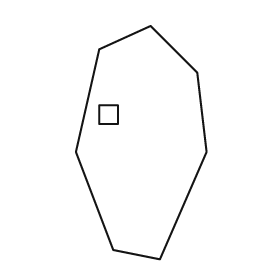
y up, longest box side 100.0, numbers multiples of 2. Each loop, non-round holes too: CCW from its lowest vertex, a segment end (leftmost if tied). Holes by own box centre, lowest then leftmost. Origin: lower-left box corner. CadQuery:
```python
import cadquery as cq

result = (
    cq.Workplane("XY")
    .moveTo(36.0, 0.0)
    .lineTo(56.0, 46.0)
    .lineTo(52.0, 80.0)
    .lineTo(32.0, 100.0)
    .lineTo(10.0, 90.0)
    .lineTo(0.0, 46.0)
    .lineTo(16.0, 4.0)
    .close()
    .moveTo(10.0, 58.0)
    .lineTo(18.0, 58.0)
    .lineTo(18.0, 66.0)
    .lineTo(10.0, 66.0)
    .close()
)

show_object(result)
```